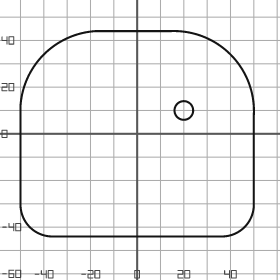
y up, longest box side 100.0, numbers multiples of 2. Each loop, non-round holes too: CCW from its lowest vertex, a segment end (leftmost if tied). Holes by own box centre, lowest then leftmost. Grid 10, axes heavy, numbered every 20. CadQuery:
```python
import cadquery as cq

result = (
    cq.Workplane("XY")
    .moveTo(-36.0, -44.0)
    .lineTo(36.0, -44.0)
    .threePointArc((46.0, -40.0), (50.0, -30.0))
    .lineTo(50.0, 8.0)
    .threePointArc((40.0, 34.0), (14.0, 44.0))
    .lineTo(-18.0, 44.0)
    .threePointArc((-40.0, 34.0), (-50.0, 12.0))
    .lineTo(-50.0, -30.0)
    .threePointArc((-46.0, -40.0), (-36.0, -44.0))
    .close()
    .moveTo(20.0, 10.0)
    .circle(4.0)
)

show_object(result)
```